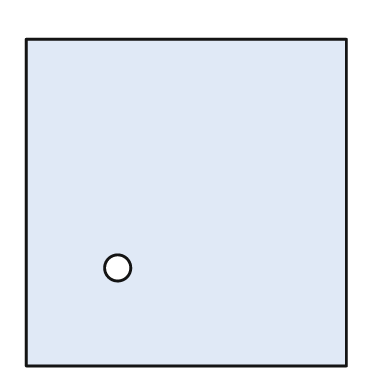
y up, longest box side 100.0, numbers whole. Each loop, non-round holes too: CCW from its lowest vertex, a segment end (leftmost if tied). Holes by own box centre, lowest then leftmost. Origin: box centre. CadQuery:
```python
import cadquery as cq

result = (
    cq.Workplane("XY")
    .moveTo(-49.0, -50.0)
    .lineTo(49.0, -50.0)
    .lineTo(49.0, 50.0)
    .lineTo(-49.0, 50.0)
    .close()
    .moveTo(-21.0, -20.0)
    .circle(4.0)
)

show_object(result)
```